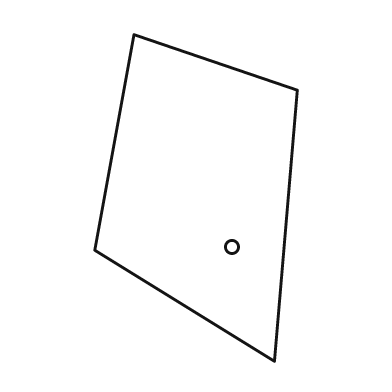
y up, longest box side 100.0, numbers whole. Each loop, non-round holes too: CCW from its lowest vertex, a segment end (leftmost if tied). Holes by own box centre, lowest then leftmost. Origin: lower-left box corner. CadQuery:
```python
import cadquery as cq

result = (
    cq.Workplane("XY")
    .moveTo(55.0, 0.0)
    .lineTo(62.0, 83.0)
    .lineTo(12.0, 100.0)
    .lineTo(0.0, 34.0)
    .close()
    .moveTo(42.0, 35.0)
    .circle(2.0)
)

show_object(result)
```